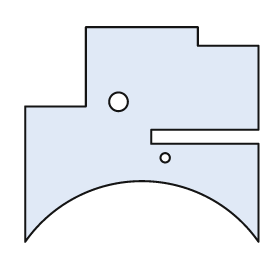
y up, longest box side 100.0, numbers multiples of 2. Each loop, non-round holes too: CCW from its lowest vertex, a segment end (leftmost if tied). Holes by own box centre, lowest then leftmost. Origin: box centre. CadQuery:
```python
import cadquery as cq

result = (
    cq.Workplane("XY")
    .moveTo(-50.0, -46.0)
    .threePointArc((0.0, -20.0), (50.0, -46.0))
    .lineTo(50.0, -4.0)
    .lineTo(4.0, -4.0)
    .lineTo(4.0, 2.0)
    .lineTo(50.0, 2.0)
    .lineTo(50.0, 38.0)
    .lineTo(24.0, 38.0)
    .lineTo(24.0, 46.0)
    .lineTo(-24.0, 46.0)
    .lineTo(-24.0, 12.0)
    .lineTo(-50.0, 12.0)
    .close()
    .moveTo(10.0, -10.0)
    .circle(2.0)
    .moveTo(-10.0, 14.0)
    .circle(4.0)
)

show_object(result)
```